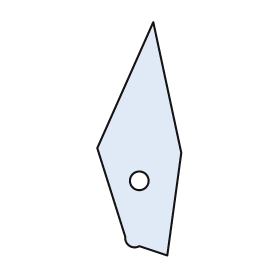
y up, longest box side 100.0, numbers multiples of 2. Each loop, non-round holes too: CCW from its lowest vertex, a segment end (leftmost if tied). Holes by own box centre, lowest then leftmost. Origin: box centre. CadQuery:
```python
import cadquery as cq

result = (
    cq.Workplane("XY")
    .moveTo(12.0, -50.0)
    .lineTo(18.0, -6.0)
    .lineTo(6.0, 50.0)
    .lineTo(-18.0, -4.0)
    .lineTo(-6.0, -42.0)
    .threePointArc((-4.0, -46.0), (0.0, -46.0))
    .close()
    .moveTo(0.0, -18.0)
    .circle(4.0)
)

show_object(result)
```